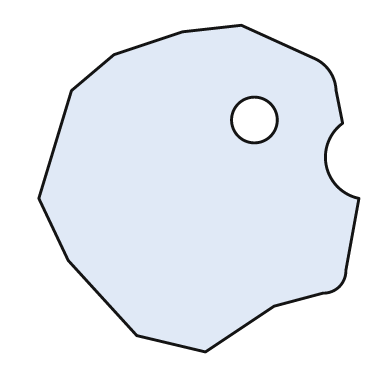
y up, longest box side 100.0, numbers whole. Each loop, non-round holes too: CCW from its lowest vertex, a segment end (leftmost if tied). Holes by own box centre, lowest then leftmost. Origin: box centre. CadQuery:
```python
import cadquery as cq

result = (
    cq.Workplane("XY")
    .moveTo(2.0, -50.0)
    .lineTo(23.0, -36.0)
    .lineTo(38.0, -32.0)
    .threePointArc((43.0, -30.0), (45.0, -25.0))
    .lineTo(49.0, -3.0)
    .threePointArc((39.0, 7.0), (44.0, 20.0))
    .lineTo(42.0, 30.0)
    .threePointArc((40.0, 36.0), (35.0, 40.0))
    .lineTo(13.0, 50.0)
    .lineTo(-5.0, 48.0)
    .lineTo(-26.0, 41.0)
    .lineTo(-39.0, 30.0)
    .lineTo(-49.0, -3.0)
    .lineTo(-40.0, -22.0)
    .lineTo(-19.0, -45.0)
    .close()
    .moveTo(17.0, 21.0)
    .circle(7.0)
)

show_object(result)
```